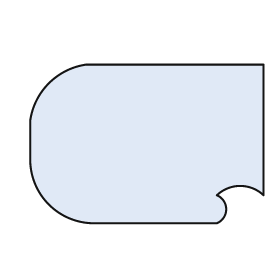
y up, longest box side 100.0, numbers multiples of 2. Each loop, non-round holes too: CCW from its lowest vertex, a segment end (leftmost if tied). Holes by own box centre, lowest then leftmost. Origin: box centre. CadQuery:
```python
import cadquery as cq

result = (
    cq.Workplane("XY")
    .moveTo(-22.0, -34.0)
    .lineTo(30.0, -34.0)
    .threePointArc((34.0, -28.0), (30.0, -22.0))
    .threePointArc((40.0, -18.0), (50.0, -22.0))
    .lineTo(50.0, 34.0)
    .lineTo(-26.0, 34.0)
    .threePointArc((-42.0, 26.0), (-50.0, 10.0))
    .lineTo(-50.0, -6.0)
    .threePointArc((-42.0, -26.0), (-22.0, -34.0))
    .close()
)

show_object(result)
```